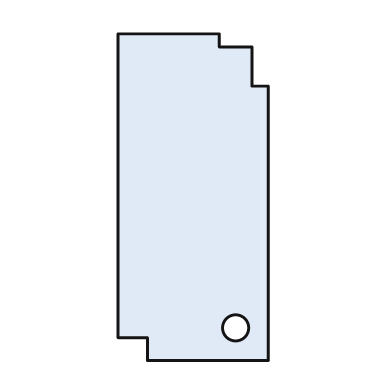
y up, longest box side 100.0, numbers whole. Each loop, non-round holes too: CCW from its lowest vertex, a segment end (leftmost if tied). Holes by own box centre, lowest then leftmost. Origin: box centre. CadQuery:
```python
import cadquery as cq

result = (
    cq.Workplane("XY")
    .moveTo(-14.0, -50.0)
    .lineTo(23.0, -50.0)
    .lineTo(23.0, 34.0)
    .lineTo(18.0, 34.0)
    .lineTo(18.0, 46.0)
    .lineTo(8.0, 46.0)
    .lineTo(8.0, 50.0)
    .lineTo(-23.0, 50.0)
    .lineTo(-23.0, -43.0)
    .lineTo(-14.0, -43.0)
    .close()
    .moveTo(13.0, -40.0)
    .circle(4.0)
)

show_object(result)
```